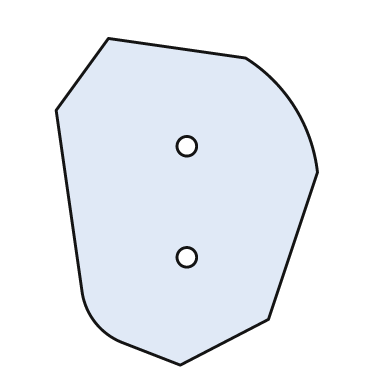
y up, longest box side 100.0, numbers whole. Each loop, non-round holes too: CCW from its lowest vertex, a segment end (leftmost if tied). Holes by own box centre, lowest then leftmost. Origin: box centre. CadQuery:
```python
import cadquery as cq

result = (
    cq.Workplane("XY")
    .moveTo(-2.0, -50.0)
    .lineTo(25.0, -36.0)
    .lineTo(40.0, 9.0)
    .threePointArc((33.0, 29.0), (18.0, 44.0))
    .lineTo(-24.0, 50.0)
    .lineTo(-40.0, 28.0)
    .lineTo(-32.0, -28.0)
    .threePointArc((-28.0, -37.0), (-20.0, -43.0))
    .close()
    .moveTo(0.0, -17.0)
    .circle(3.0)
    .moveTo(0.0, 17.0)
    .circle(3.0)
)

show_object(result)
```